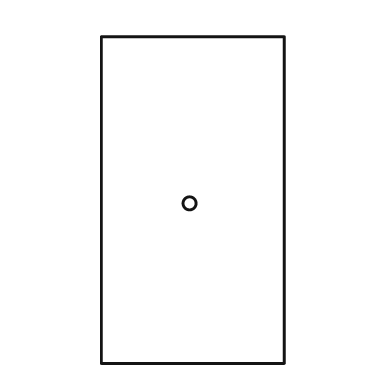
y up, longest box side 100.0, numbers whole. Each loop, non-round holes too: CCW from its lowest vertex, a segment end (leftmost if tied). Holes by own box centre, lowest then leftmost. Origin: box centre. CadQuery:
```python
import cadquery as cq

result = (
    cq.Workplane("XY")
    .moveTo(-28.0, -50.0)
    .lineTo(28.0, -50.0)
    .lineTo(28.0, 50.0)
    .lineTo(-28.0, 50.0)
    .close()
    .moveTo(-1.0, -1.0)
    .circle(2.0)
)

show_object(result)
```